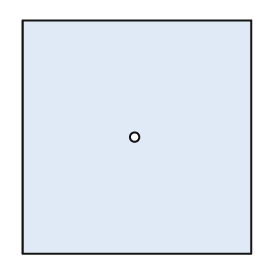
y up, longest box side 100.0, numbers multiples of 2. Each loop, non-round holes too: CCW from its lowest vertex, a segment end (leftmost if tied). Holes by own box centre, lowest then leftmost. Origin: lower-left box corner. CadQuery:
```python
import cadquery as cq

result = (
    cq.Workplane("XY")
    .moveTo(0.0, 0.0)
    .lineTo(98.0, 0.0)
    .lineTo(98.0, 100.0)
    .lineTo(0.0, 100.0)
    .close()
    .moveTo(48.0, 50.0)
    .circle(2.0)
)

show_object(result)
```